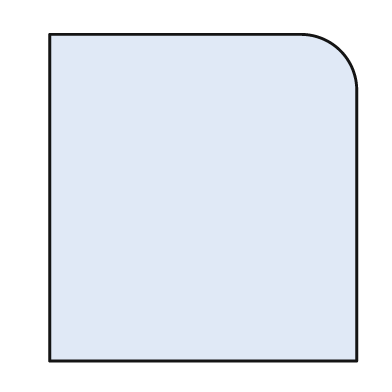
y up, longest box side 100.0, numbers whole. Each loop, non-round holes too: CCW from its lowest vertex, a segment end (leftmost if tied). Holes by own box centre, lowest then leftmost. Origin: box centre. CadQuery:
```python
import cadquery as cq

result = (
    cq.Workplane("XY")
    .moveTo(-47.0, -50.0)
    .lineTo(47.0, -50.0)
    .lineTo(47.0, 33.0)
    .threePointArc((42.0, 45.0), (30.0, 50.0))
    .lineTo(-47.0, 50.0)
    .close()
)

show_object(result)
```